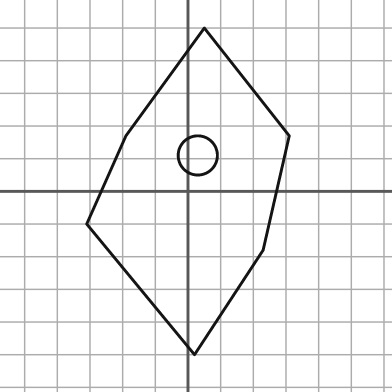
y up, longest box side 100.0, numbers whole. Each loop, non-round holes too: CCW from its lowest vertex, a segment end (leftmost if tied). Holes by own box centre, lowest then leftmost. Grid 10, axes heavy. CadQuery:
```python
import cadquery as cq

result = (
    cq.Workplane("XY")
    .moveTo(2.0, -50.0)
    .lineTo(23.0, -18.0)
    .lineTo(31.0, 17.0)
    .lineTo(5.0, 50.0)
    .lineTo(-19.0, 17.0)
    .lineTo(-31.0, -10.0)
    .close()
    .moveTo(3.0, 11.0)
    .circle(6.0)
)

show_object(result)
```